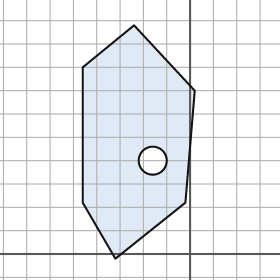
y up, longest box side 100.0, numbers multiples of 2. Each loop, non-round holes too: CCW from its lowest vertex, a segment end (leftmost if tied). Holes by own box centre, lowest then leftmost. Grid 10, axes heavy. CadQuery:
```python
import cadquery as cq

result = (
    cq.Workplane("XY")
    .moveTo(-32.0, -2.0)
    .lineTo(-2.0, 22.0)
    .lineTo(2.0, 70.0)
    .lineTo(-24.0, 98.0)
    .lineTo(-46.0, 80.0)
    .lineTo(-46.0, 22.0)
    .close()
    .moveTo(-16.0, 40.0)
    .circle(6.0)
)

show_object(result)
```